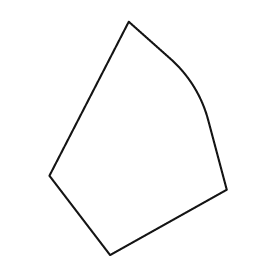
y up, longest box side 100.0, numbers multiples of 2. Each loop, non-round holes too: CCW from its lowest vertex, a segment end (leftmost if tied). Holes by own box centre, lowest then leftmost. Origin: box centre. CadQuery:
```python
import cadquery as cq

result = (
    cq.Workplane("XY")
    .moveTo(-12.0, -50.0)
    .lineTo(38.0, -22.0)
    .lineTo(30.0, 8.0)
    .threePointArc((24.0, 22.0), (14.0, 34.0))
    .lineTo(-4.0, 50.0)
    .lineTo(-38.0, -16.0)
    .close()
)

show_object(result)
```